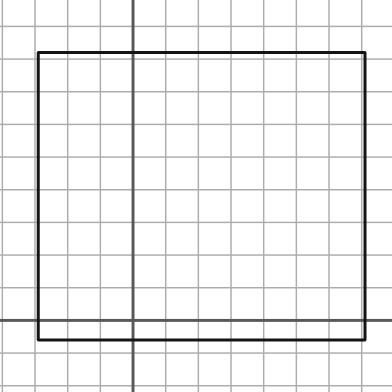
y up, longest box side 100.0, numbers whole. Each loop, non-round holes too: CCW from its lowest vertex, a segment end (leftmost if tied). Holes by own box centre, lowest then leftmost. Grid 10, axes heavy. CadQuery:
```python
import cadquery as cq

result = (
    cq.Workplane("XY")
    .moveTo(-29.0, -6.0)
    .lineTo(71.0, -6.0)
    .lineTo(71.0, 82.0)
    .lineTo(-29.0, 82.0)
    .close()
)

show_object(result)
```